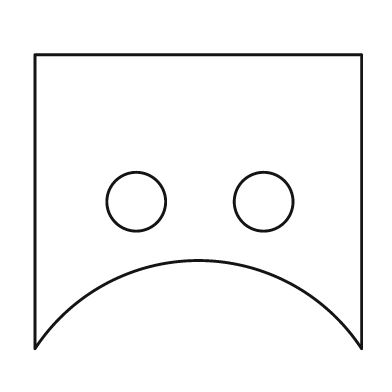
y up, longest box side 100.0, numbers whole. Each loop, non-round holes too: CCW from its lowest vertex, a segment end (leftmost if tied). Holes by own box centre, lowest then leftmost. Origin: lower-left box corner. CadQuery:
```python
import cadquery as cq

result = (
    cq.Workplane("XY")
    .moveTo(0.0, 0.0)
    .threePointArc((50.0, 27.0), (100.0, 0.0))
    .lineTo(100.0, 90.0)
    .lineTo(0.0, 90.0)
    .close()
    .moveTo(31.0, 45.0)
    .circle(9.0)
    .moveTo(70.0, 45.0)
    .circle(9.0)
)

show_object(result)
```